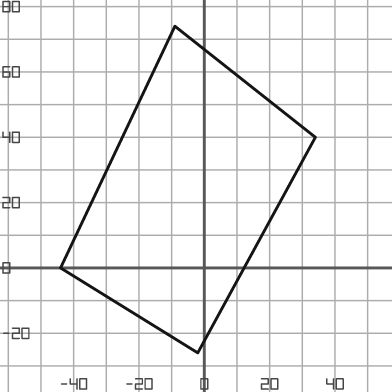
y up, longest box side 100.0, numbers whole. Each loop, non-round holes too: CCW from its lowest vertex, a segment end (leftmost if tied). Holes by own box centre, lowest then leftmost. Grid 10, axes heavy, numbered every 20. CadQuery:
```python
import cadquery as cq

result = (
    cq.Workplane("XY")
    .moveTo(-2.0, -26.0)
    .lineTo(34.0, 40.0)
    .lineTo(-9.0, 74.0)
    .lineTo(-44.0, 0.0)
    .close()
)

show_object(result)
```